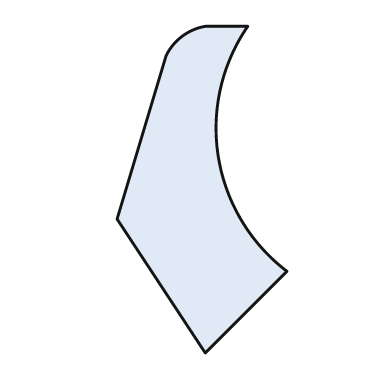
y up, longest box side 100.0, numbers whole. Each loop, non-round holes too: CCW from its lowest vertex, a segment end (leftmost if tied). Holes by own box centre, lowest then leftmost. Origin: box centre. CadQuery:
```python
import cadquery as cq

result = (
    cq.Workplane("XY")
    .moveTo(1.0, -50.0)
    .lineTo(26.0, -25.0)
    .threePointArc((5.0, 10.0), (14.0, 50.0))
    .lineTo(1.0, 50.0)
    .threePointArc((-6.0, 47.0), (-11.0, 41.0))
    .lineTo(-26.0, -9.0)
    .close()
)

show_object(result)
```